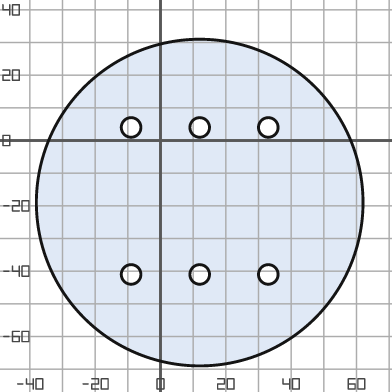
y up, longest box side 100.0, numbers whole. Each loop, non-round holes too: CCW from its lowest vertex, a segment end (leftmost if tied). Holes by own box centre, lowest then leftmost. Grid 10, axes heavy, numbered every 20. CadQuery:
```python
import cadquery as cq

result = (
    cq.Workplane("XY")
    .moveTo(12.0, -19.0)
    .circle(50.0)
    .moveTo(-9.0, -41.0)
    .circle(3.0)
    .moveTo(12.0, -41.0)
    .circle(3.0)
    .moveTo(33.0, -41.0)
    .circle(3.0)
    .moveTo(-9.0, 4.0)
    .circle(3.0)
    .moveTo(12.0, 4.0)
    .circle(3.0)
    .moveTo(33.0, 4.0)
    .circle(3.0)
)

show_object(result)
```